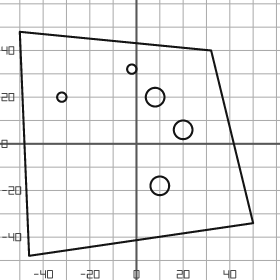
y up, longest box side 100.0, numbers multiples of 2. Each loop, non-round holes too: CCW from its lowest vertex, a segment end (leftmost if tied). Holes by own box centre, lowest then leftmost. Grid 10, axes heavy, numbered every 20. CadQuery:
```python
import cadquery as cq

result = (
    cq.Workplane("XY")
    .moveTo(-46.0, -48.0)
    .lineTo(50.0, -34.0)
    .lineTo(32.0, 40.0)
    .lineTo(-50.0, 48.0)
    .close()
    .moveTo(10.0, -18.0)
    .circle(4.0)
    .moveTo(20.0, 6.0)
    .circle(4.0)
    .moveTo(-32.0, 20.0)
    .circle(2.0)
    .moveTo(8.0, 20.0)
    .circle(4.0)
    .moveTo(-2.0, 32.0)
    .circle(2.0)
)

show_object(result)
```